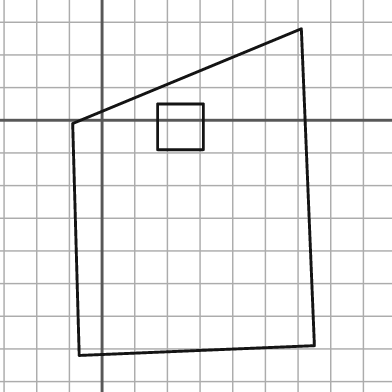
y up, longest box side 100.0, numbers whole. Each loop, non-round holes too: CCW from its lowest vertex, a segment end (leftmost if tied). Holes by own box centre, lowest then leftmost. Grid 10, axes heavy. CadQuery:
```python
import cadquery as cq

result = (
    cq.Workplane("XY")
    .moveTo(-7.0, -72.0)
    .lineTo(65.0, -69.0)
    .lineTo(61.0, 28.0)
    .lineTo(-9.0, -1.0)
    .close()
    .moveTo(17.0, -9.0)
    .lineTo(31.0, -9.0)
    .lineTo(31.0, 5.0)
    .lineTo(17.0, 5.0)
    .close()
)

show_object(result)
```